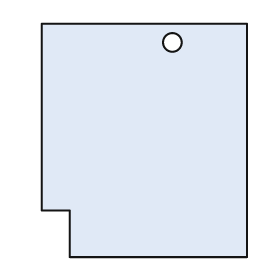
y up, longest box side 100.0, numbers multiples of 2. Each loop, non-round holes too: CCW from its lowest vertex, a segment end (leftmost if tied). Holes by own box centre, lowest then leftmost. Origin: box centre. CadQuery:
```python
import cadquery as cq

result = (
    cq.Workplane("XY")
    .moveTo(-32.0, -50.0)
    .lineTo(44.0, -50.0)
    .lineTo(44.0, 50.0)
    .lineTo(-44.0, 50.0)
    .lineTo(-44.0, -30.0)
    .lineTo(-32.0, -30.0)
    .close()
    .moveTo(12.0, 42.0)
    .circle(4.0)
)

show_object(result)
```